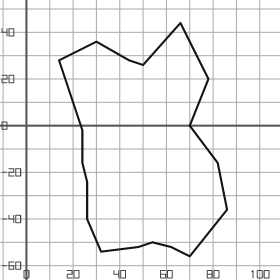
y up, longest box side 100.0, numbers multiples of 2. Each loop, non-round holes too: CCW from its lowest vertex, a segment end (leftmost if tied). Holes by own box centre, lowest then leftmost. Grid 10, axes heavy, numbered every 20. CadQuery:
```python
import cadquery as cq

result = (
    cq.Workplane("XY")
    .moveTo(70.0, -56.0)
    .lineTo(86.0, -36.0)
    .lineTo(82.0, -16.0)
    .lineTo(70.0, 0.0)
    .lineTo(78.0, 20.0)
    .lineTo(66.0, 44.0)
    .lineTo(50.0, 26.0)
    .lineTo(44.0, 28.0)
    .lineTo(30.0, 36.0)
    .lineTo(14.0, 28.0)
    .lineTo(24.0, -2.0)
    .lineTo(24.0, -16.0)
    .lineTo(26.0, -24.0)
    .lineTo(26.0, -40.0)
    .lineTo(32.0, -54.0)
    .lineTo(48.0, -52.0)
    .lineTo(54.0, -50.0)
    .lineTo(62.0, -52.0)
    .close()
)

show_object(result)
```